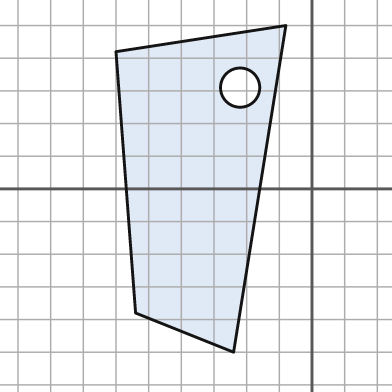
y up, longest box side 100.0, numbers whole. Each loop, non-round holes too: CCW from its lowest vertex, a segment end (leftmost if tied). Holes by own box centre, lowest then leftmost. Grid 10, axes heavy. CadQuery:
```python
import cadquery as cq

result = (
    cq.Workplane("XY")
    .moveTo(-24.0, -50.0)
    .lineTo(-8.0, 50.0)
    .lineTo(-60.0, 42.0)
    .lineTo(-54.0, -38.0)
    .close()
    .moveTo(-22.0, 31.0)
    .circle(6.0)
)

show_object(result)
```